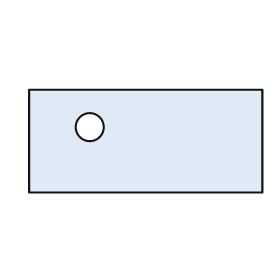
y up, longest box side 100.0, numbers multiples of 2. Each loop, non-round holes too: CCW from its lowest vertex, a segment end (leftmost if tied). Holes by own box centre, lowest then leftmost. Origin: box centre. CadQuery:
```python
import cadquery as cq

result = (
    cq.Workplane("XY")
    .moveTo(-50.0, -22.0)
    .lineTo(50.0, -22.0)
    .lineTo(50.0, 22.0)
    .lineTo(-50.0, 22.0)
    .close()
    .moveTo(-24.0, 6.0)
    .circle(6.0)
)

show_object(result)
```